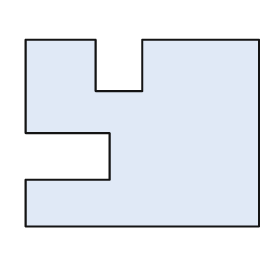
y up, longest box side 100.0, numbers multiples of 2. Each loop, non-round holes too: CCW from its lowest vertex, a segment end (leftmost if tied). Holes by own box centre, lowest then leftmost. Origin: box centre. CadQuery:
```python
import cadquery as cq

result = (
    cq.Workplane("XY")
    .moveTo(-50.0, -40.0)
    .lineTo(50.0, -40.0)
    .lineTo(50.0, 40.0)
    .lineTo(0.0, 40.0)
    .lineTo(0.0, 18.0)
    .lineTo(-20.0, 18.0)
    .lineTo(-20.0, 40.0)
    .lineTo(-50.0, 40.0)
    .lineTo(-50.0, 0.0)
    .lineTo(-14.0, 0.0)
    .lineTo(-14.0, -20.0)
    .lineTo(-50.0, -20.0)
    .close()
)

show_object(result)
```